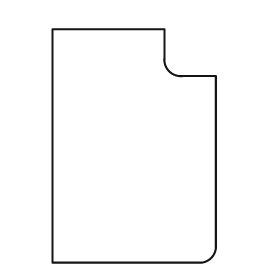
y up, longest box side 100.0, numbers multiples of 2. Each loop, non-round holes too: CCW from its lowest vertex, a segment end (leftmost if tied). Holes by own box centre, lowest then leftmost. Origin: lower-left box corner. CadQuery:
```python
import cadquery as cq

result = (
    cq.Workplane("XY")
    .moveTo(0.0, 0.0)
    .lineTo(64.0, 0.0)
    .threePointArc((68.0, 2.0), (70.0, 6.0))
    .lineTo(70.0, 80.0)
    .lineTo(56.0, 80.0)
    .threePointArc((50.0, 82.0), (48.0, 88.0))
    .lineTo(48.0, 100.0)
    .lineTo(0.0, 100.0)
    .close()
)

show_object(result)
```